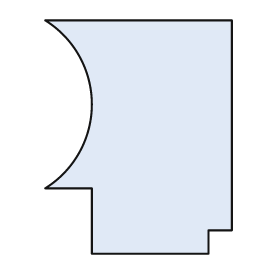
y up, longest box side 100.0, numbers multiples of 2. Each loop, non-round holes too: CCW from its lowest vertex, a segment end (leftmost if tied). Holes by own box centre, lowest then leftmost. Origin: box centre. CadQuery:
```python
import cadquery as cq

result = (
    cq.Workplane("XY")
    .moveTo(-20.0, -50.0)
    .lineTo(30.0, -50.0)
    .lineTo(30.0, -40.0)
    .lineTo(40.0, -40.0)
    .lineTo(40.0, 50.0)
    .lineTo(-40.0, 50.0)
    .threePointArc((-20.0, 14.0), (-40.0, -22.0))
    .lineTo(-20.0, -22.0)
    .close()
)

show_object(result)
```